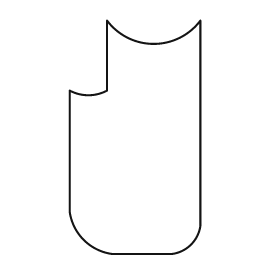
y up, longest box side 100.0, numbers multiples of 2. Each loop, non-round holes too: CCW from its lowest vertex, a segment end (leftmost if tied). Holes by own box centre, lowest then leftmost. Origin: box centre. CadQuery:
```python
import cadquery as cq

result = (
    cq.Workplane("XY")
    .moveTo(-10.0, -50.0)
    .lineTo(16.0, -50.0)
    .threePointArc((24.0, -46.0), (28.0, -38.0))
    .lineTo(28.0, 50.0)
    .threePointArc((8.0, 40.0), (-12.0, 50.0))
    .lineTo(-12.0, 20.0)
    .threePointArc((-20.0, 18.0), (-28.0, 20.0))
    .lineTo(-28.0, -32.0)
    .threePointArc((-22.0, -44.0), (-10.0, -50.0))
    .close()
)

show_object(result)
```